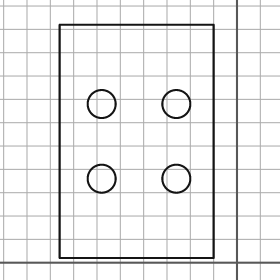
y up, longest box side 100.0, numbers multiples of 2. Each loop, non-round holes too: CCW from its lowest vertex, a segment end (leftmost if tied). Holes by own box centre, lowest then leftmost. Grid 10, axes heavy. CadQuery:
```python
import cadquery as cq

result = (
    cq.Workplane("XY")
    .moveTo(-76.0, 2.0)
    .lineTo(-10.0, 2.0)
    .lineTo(-10.0, 102.0)
    .lineTo(-76.0, 102.0)
    .close()
    .moveTo(-58.0, 36.0)
    .circle(6.0)
    .moveTo(-26.0, 36.0)
    .circle(6.0)
    .moveTo(-58.0, 68.0)
    .circle(6.0)
    .moveTo(-26.0, 68.0)
    .circle(6.0)
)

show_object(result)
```